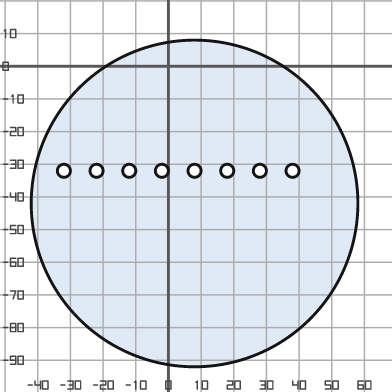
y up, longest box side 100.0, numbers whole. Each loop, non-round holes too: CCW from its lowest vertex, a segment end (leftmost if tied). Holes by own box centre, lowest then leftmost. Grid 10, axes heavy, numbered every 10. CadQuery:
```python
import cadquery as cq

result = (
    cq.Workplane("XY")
    .moveTo(8.0, -42.0)
    .circle(50.0)
    .moveTo(-32.0, -32.0)
    .circle(2.0)
    .moveTo(-22.0, -32.0)
    .circle(2.0)
    .moveTo(-12.0, -32.0)
    .circle(2.0)
    .moveTo(-2.0, -32.0)
    .circle(2.0)
    .moveTo(8.0, -32.0)
    .circle(2.0)
    .moveTo(18.0, -32.0)
    .circle(2.0)
    .moveTo(28.0, -32.0)
    .circle(2.0)
    .moveTo(38.0, -32.0)
    .circle(2.0)
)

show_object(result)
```